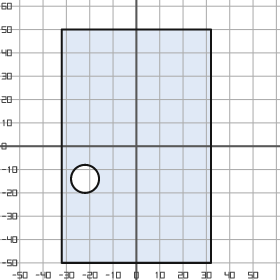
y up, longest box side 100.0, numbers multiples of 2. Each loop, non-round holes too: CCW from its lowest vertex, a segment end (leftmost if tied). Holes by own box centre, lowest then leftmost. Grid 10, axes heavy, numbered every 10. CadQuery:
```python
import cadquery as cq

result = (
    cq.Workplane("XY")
    .moveTo(-32.0, -50.0)
    .lineTo(32.0, -50.0)
    .lineTo(32.0, 50.0)
    .lineTo(-32.0, 50.0)
    .close()
    .moveTo(-22.0, -14.0)
    .circle(6.0)
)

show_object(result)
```